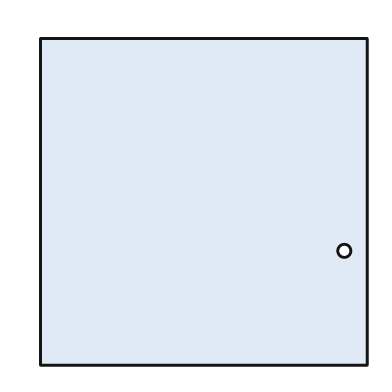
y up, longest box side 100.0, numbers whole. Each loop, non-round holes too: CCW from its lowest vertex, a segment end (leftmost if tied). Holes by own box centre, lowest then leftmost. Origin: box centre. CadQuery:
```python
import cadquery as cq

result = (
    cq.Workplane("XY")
    .moveTo(-50.0, -50.0)
    .lineTo(50.0, -50.0)
    .lineTo(50.0, 50.0)
    .lineTo(-50.0, 50.0)
    .close()
    .moveTo(43.0, -15.0)
    .circle(2.0)
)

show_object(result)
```